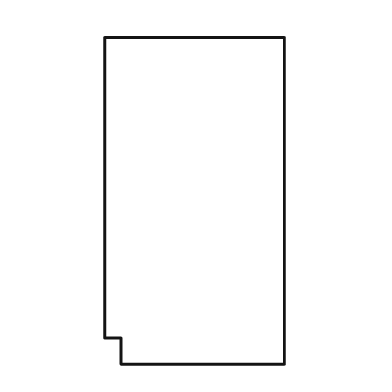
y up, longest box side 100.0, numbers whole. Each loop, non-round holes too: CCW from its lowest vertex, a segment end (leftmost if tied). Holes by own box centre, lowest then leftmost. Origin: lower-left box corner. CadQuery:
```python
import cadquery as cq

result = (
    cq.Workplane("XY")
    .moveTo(5.0, 0.0)
    .lineTo(55.0, 0.0)
    .lineTo(55.0, 100.0)
    .lineTo(0.0, 100.0)
    .lineTo(0.0, 8.0)
    .lineTo(5.0, 8.0)
    .close()
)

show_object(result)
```